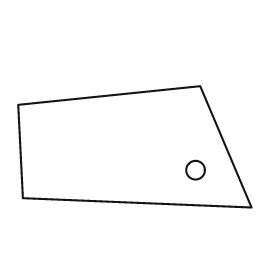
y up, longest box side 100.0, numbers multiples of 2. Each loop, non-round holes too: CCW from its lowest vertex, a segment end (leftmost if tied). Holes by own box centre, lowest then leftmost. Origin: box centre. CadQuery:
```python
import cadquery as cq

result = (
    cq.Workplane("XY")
    .moveTo(50.0, -26.0)
    .lineTo(28.0, 26.0)
    .lineTo(-50.0, 18.0)
    .lineTo(-48.0, -22.0)
    .close()
    .moveTo(26.0, -10.0)
    .circle(4.0)
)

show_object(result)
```